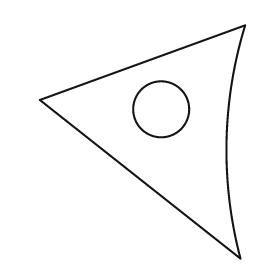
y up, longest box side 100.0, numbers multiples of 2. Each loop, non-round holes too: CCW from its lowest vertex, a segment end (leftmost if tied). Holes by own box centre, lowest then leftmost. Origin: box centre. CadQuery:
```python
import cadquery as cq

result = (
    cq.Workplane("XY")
    .moveTo(42.0, -50.0)
    .threePointArc((36.0, 0.0), (44.0, 50.0))
    .lineTo(-44.0, 18.0)
    .close()
    .moveTo(8.0, 14.0)
    .circle(12.0)
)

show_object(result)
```